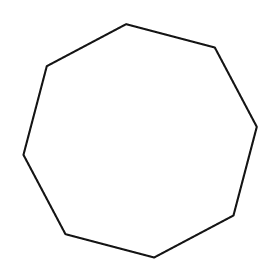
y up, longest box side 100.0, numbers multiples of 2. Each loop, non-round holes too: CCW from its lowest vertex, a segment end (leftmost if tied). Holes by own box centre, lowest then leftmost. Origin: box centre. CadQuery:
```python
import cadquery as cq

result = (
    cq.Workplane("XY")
    .moveTo(6.0, -50.0)
    .lineTo(40.0, -32.0)
    .lineTo(50.0, 6.0)
    .lineTo(32.0, 40.0)
    .lineTo(-6.0, 50.0)
    .lineTo(-40.0, 32.0)
    .lineTo(-50.0, -6.0)
    .lineTo(-32.0, -40.0)
    .close()
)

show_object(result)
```